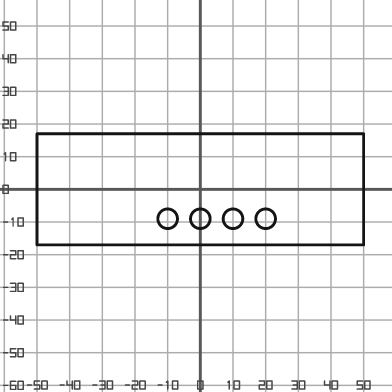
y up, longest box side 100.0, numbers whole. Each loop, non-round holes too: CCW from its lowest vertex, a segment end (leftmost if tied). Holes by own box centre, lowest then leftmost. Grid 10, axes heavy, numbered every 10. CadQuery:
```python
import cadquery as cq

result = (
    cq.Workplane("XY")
    .moveTo(-50.0, -17.0)
    .lineTo(50.0, -17.0)
    .lineTo(50.0, 17.0)
    .lineTo(-50.0, 17.0)
    .close()
    .moveTo(-10.0, -9.0)
    .circle(3.0)
    .moveTo(0.0, -9.0)
    .circle(3.0)
    .moveTo(10.0, -9.0)
    .circle(3.0)
    .moveTo(20.0, -9.0)
    .circle(3.0)
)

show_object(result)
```